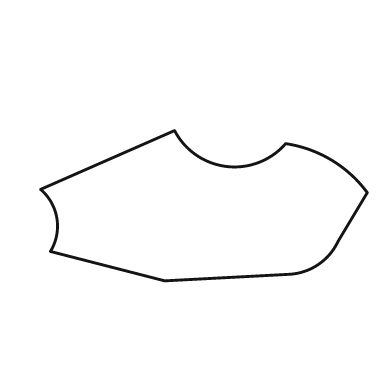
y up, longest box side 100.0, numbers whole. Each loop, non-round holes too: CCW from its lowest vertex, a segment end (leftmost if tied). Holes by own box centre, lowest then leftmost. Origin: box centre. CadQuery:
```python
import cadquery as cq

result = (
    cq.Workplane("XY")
    .moveTo(-12.0, -23.0)
    .lineTo(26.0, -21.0)
    .threePointArc((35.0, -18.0), (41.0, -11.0))
    .lineTo(50.0, 4.0)
    .threePointArc((39.0, 14.0), (25.0, 19.0))
    .threePointArc((7.0, 12.0), (-9.0, 23.0))
    .lineTo(-50.0, 5.0)
    .threePointArc((-45.0, -4.0), (-47.0, -14.0))
    .close()
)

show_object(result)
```